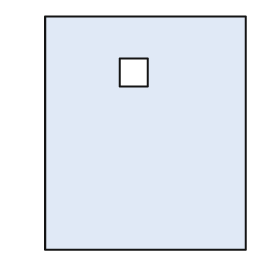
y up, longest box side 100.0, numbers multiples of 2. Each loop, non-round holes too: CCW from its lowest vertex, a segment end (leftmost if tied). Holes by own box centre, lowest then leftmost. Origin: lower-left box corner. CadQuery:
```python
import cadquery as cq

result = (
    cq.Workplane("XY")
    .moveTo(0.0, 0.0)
    .lineTo(86.0, 0.0)
    .lineTo(86.0, 100.0)
    .lineTo(0.0, 100.0)
    .close()
    .moveTo(32.0, 70.0)
    .lineTo(44.0, 70.0)
    .lineTo(44.0, 82.0)
    .lineTo(32.0, 82.0)
    .close()
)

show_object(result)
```